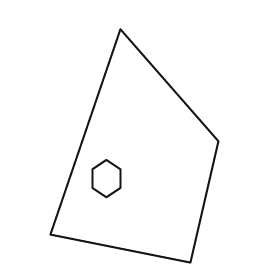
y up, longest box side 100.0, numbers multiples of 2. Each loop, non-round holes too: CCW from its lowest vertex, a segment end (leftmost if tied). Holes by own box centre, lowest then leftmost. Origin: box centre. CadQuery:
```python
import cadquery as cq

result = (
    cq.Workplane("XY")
    .moveTo(24.0, -50.0)
    .lineTo(36.0, 2.0)
    .lineTo(-6.0, 50.0)
    .lineTo(-36.0, -38.0)
    .close()
    .moveTo(-12.0, -22.0)
    .lineTo(-6.0, -18.0)
    .lineTo(-6.0, -10.0)
    .lineTo(-12.0, -6.0)
    .lineTo(-18.0, -10.0)
    .lineTo(-18.0, -18.0)
    .close()
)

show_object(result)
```